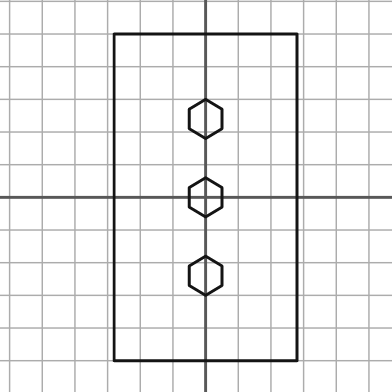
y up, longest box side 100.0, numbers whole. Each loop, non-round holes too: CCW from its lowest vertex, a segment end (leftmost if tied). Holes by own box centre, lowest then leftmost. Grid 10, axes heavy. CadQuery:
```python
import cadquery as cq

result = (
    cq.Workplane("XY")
    .moveTo(-28.0, -50.0)
    .lineTo(28.0, -50.0)
    .lineTo(28.0, 50.0)
    .lineTo(-28.0, 50.0)
    .close()
    .moveTo(0.0, -30.0)
    .lineTo(5.0, -27.0)
    .lineTo(5.0, -21.0)
    .lineTo(0.0, -18.0)
    .lineTo(-5.0, -21.0)
    .lineTo(-5.0, -27.0)
    .close()
    .moveTo(0.0, -6.0)
    .lineTo(5.0, -3.0)
    .lineTo(5.0, 3.0)
    .lineTo(0.0, 6.0)
    .lineTo(-5.0, 3.0)
    .lineTo(-5.0, -3.0)
    .close()
    .moveTo(0.0, 18.0)
    .lineTo(5.0, 21.0)
    .lineTo(5.0, 27.0)
    .lineTo(0.0, 30.0)
    .lineTo(-5.0, 27.0)
    .lineTo(-5.0, 21.0)
    .close()
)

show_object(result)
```